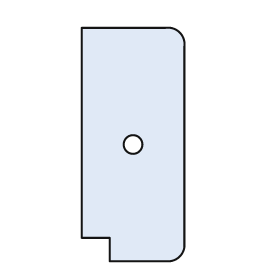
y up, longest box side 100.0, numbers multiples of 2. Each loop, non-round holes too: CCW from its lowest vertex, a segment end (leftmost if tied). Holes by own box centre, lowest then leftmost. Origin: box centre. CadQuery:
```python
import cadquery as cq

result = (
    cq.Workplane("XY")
    .moveTo(-10.0, -50.0)
    .lineTo(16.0, -50.0)
    .threePointArc((20.0, -48.0), (22.0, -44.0))
    .lineTo(22.0, 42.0)
    .threePointArc((20.0, 48.0), (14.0, 50.0))
    .lineTo(-22.0, 50.0)
    .lineTo(-22.0, -40.0)
    .lineTo(-10.0, -40.0)
    .close()
    .moveTo(0.0, 0.0)
    .circle(4.0)
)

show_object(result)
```